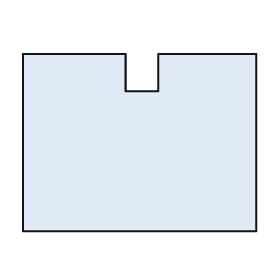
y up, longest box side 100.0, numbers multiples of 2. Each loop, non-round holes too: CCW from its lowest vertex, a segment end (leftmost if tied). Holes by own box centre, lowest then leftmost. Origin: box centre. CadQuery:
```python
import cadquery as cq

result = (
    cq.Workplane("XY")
    .moveTo(-50.0, -38.0)
    .lineTo(50.0, -38.0)
    .lineTo(50.0, 38.0)
    .lineTo(8.0, 38.0)
    .lineTo(8.0, 22.0)
    .lineTo(-6.0, 22.0)
    .lineTo(-6.0, 38.0)
    .lineTo(-50.0, 38.0)
    .close()
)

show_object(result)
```